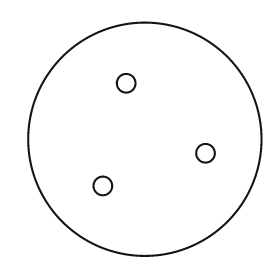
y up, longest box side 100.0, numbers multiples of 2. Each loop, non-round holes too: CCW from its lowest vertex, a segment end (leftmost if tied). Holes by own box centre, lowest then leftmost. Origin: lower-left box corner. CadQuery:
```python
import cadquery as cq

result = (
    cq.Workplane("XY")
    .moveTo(50.0, 50.0)
    .circle(50.0)
    .moveTo(32.0, 30.0)
    .circle(4.0)
    .moveTo(76.0, 44.0)
    .circle(4.0)
    .moveTo(42.0, 74.0)
    .circle(4.0)
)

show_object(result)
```